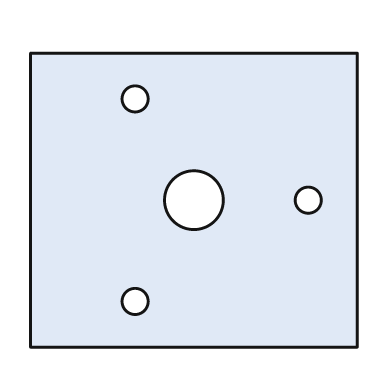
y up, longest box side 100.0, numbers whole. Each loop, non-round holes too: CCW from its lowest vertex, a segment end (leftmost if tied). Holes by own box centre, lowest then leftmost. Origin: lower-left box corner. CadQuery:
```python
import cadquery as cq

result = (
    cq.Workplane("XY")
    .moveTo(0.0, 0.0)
    .lineTo(100.0, 0.0)
    .lineTo(100.0, 90.0)
    .lineTo(0.0, 90.0)
    .close()
    .moveTo(32.0, 14.0)
    .circle(4.0)
    .moveTo(50.0, 45.0)
    .circle(9.0)
    .moveTo(85.0, 45.0)
    .circle(4.0)
    .moveTo(32.0, 76.0)
    .circle(4.0)
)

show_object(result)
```